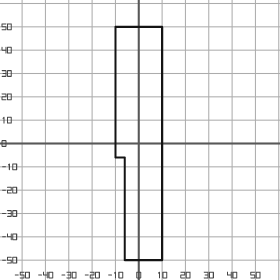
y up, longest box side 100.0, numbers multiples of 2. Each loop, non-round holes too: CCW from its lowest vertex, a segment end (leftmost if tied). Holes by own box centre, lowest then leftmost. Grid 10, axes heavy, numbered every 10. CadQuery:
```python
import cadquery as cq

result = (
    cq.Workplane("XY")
    .moveTo(-6.0, -50.0)
    .lineTo(10.0, -50.0)
    .lineTo(10.0, 50.0)
    .lineTo(-10.0, 50.0)
    .lineTo(-10.0, -6.0)
    .lineTo(-6.0, -6.0)
    .close()
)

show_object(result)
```